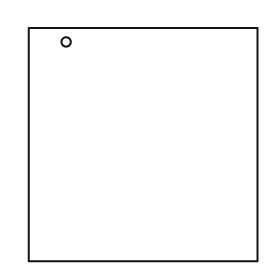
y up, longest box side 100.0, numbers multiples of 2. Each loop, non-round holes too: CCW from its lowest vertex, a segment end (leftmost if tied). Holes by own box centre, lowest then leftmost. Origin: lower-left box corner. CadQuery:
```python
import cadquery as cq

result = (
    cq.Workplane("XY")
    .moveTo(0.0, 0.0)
    .lineTo(98.0, 0.0)
    .lineTo(98.0, 100.0)
    .lineTo(0.0, 100.0)
    .close()
    .moveTo(16.0, 94.0)
    .circle(2.0)
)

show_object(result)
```